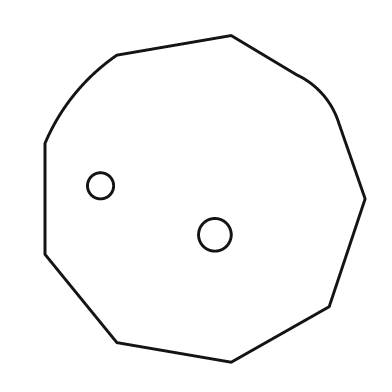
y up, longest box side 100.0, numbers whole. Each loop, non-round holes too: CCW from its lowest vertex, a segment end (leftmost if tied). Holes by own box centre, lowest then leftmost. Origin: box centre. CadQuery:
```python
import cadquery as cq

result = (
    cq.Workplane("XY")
    .moveTo(8.0, -50.0)
    .lineTo(38.0, -33.0)
    .lineTo(49.0, 0.0)
    .lineTo(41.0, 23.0)
    .threePointArc((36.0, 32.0), (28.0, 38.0))
    .lineTo(8.0, 50.0)
    .lineTo(-27.0, 44.0)
    .threePointArc((-40.0, 32.0), (-49.0, 17.0))
    .lineTo(-49.0, -17.0)
    .lineTo(-27.0, -44.0)
    .close()
    .moveTo(3.0, -11.0)
    .circle(5.0)
    .moveTo(-32.0, 4.0)
    .circle(4.0)
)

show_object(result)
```